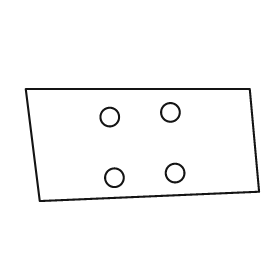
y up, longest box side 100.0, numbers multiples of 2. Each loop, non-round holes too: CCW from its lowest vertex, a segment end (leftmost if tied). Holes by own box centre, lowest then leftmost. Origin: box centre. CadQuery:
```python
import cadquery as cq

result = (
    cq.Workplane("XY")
    .moveTo(-44.0, -24.0)
    .lineTo(50.0, -20.0)
    .lineTo(46.0, 24.0)
    .lineTo(-50.0, 24.0)
    .close()
    .moveTo(-12.0, -14.0)
    .circle(4.0)
    .moveTo(14.0, -12.0)
    .circle(4.0)
    .moveTo(-14.0, 12.0)
    .circle(4.0)
    .moveTo(12.0, 14.0)
    .circle(4.0)
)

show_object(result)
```